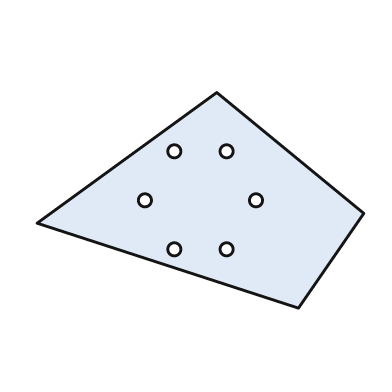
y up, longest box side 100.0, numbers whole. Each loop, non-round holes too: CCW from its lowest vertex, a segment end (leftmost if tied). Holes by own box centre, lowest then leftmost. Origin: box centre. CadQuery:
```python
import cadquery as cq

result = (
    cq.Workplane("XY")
    .moveTo(30.0, -33.0)
    .lineTo(50.0, -4.0)
    .lineTo(5.0, 33.0)
    .lineTo(-50.0, -7.0)
    .close()
    .moveTo(-8.0, -15.0)
    .circle(2.0)
    .moveTo(8.0, -15.0)
    .circle(2.0)
    .moveTo(-17.0, 0.0)
    .circle(2.0)
    .moveTo(17.0, 0.0)
    .circle(2.0)
    .moveTo(-8.0, 15.0)
    .circle(2.0)
    .moveTo(8.0, 15.0)
    .circle(2.0)
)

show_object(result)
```